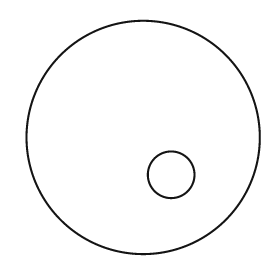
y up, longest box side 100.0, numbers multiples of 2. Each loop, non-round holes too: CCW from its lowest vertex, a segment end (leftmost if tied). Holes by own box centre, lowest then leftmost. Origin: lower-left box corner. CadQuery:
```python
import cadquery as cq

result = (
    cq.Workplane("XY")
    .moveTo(50.0, 50.0)
    .circle(50.0)
    .moveTo(62.0, 34.0)
    .circle(10.0)
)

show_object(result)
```